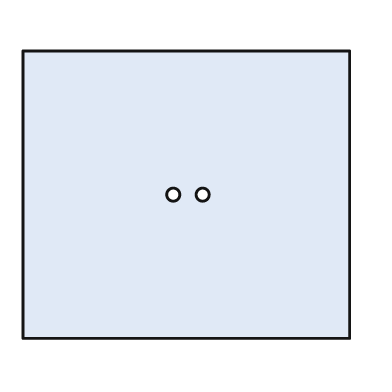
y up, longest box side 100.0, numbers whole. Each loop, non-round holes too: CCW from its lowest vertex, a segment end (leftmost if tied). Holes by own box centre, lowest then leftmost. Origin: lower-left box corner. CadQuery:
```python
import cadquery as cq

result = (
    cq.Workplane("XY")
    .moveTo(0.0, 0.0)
    .lineTo(100.0, 0.0)
    .lineTo(100.0, 88.0)
    .lineTo(0.0, 88.0)
    .close()
    .moveTo(46.0, 44.0)
    .circle(2.0)
    .moveTo(55.0, 44.0)
    .circle(2.0)
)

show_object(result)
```